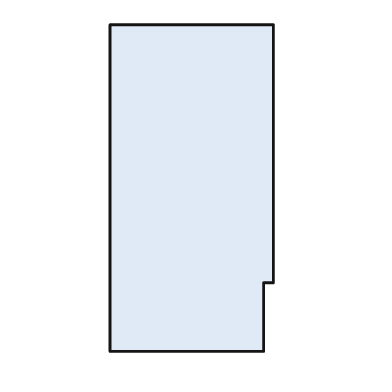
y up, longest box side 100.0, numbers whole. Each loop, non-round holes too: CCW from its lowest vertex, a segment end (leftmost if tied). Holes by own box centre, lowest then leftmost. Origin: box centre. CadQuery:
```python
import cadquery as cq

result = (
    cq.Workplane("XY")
    .moveTo(-25.0, -50.0)
    .lineTo(22.0, -50.0)
    .lineTo(22.0, -29.0)
    .lineTo(25.0, -29.0)
    .lineTo(25.0, 50.0)
    .lineTo(-25.0, 50.0)
    .close()
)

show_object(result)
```